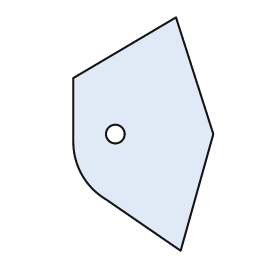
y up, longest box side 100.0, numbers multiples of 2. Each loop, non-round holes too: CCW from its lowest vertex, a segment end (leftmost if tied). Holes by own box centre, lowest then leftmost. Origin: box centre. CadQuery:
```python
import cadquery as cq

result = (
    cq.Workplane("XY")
    .moveTo(16.0, -50.0)
    .lineTo(30.0, 0.0)
    .lineTo(14.0, 50.0)
    .lineTo(-30.0, 24.0)
    .lineTo(-30.0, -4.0)
    .threePointArc((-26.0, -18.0), (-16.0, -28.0))
    .close()
    .moveTo(-12.0, 0.0)
    .circle(4.0)
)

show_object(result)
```